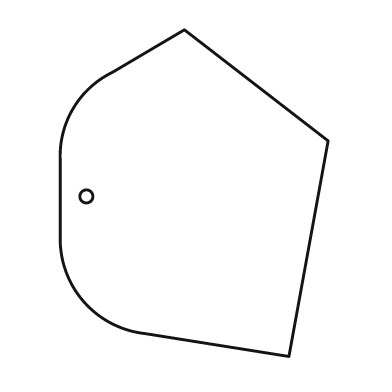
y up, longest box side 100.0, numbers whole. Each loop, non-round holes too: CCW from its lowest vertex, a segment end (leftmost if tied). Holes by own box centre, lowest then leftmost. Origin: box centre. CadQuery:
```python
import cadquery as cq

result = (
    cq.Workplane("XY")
    .moveTo(29.0, -50.0)
    .lineTo(41.0, 16.0)
    .lineTo(-3.0, 50.0)
    .lineTo(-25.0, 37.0)
    .threePointArc((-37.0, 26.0), (-41.0, 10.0))
    .lineTo(-41.0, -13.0)
    .threePointArc((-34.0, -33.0), (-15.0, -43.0))
    .close()
    .moveTo(-33.0, -1.0)
    .circle(2.0)
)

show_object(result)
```